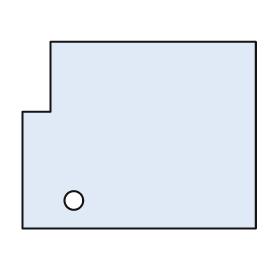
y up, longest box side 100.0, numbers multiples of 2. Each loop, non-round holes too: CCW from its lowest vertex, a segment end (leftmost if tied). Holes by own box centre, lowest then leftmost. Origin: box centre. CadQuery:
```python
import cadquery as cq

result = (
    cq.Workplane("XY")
    .moveTo(-50.0, -40.0)
    .lineTo(50.0, -40.0)
    .lineTo(50.0, 40.0)
    .lineTo(-38.0, 40.0)
    .lineTo(-38.0, 10.0)
    .lineTo(-50.0, 10.0)
    .close()
    .moveTo(-28.0, -28.0)
    .circle(4.0)
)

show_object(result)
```